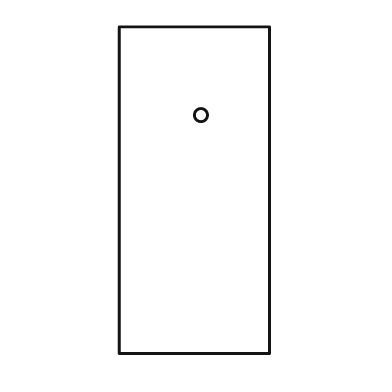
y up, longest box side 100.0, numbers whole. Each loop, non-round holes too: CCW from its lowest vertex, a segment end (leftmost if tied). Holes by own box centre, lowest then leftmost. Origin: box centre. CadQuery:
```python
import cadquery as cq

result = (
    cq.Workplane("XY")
    .moveTo(-23.0, -50.0)
    .lineTo(23.0, -50.0)
    .lineTo(23.0, 50.0)
    .lineTo(-23.0, 50.0)
    .close()
    .moveTo(2.0, 23.0)
    .circle(2.0)
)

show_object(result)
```